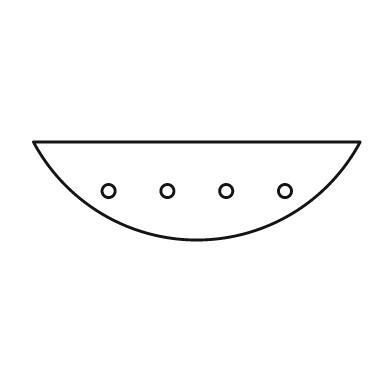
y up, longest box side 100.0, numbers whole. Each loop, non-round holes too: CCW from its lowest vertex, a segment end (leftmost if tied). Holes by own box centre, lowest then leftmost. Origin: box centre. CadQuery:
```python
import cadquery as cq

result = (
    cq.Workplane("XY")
    .moveTo(-50.0, 15.0)
    .threePointArc((0.0, -15.0), (50.0, 15.0))
    .close()
    .moveTo(-27.0, 0.0)
    .circle(2.0)
    .moveTo(-9.0, 0.0)
    .circle(2.0)
    .moveTo(9.0, 0.0)
    .circle(2.0)
    .moveTo(27.0, 0.0)
    .circle(2.0)
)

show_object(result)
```